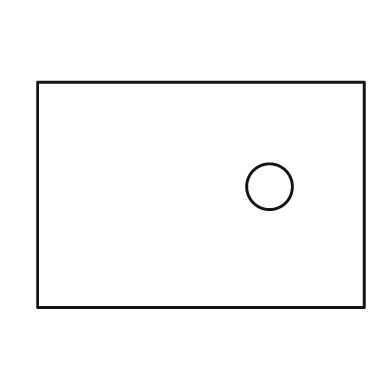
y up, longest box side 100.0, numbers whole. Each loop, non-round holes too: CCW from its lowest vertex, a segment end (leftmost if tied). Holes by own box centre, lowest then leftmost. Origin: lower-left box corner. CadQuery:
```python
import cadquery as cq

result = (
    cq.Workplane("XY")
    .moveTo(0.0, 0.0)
    .lineTo(100.0, 0.0)
    .lineTo(100.0, 69.0)
    .lineTo(0.0, 69.0)
    .close()
    .moveTo(71.0, 37.0)
    .circle(7.0)
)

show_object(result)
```